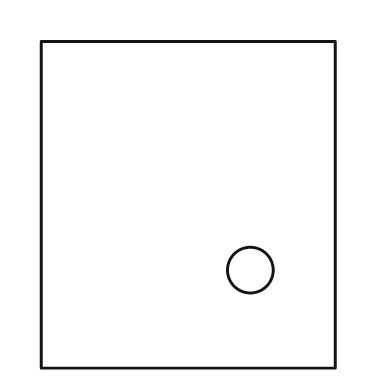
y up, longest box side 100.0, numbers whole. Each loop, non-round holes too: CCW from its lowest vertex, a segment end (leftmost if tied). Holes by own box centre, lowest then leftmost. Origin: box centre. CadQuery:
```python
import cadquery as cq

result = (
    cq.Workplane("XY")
    .moveTo(-45.0, -50.0)
    .lineTo(45.0, -50.0)
    .lineTo(45.0, 50.0)
    .lineTo(-45.0, 50.0)
    .close()
    .moveTo(19.0, -20.0)
    .circle(7.0)
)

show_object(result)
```